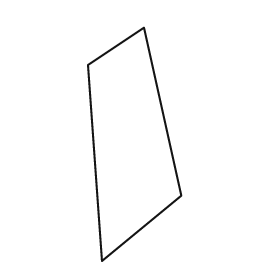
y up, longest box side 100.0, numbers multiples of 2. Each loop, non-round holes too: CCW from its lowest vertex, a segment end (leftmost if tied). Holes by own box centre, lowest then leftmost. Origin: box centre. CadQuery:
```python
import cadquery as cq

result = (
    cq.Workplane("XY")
    .moveTo(-14.0, -50.0)
    .lineTo(20.0, -22.0)
    .lineTo(4.0, 50.0)
    .lineTo(-20.0, 34.0)
    .close()
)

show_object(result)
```